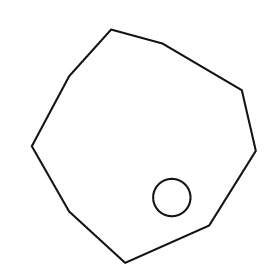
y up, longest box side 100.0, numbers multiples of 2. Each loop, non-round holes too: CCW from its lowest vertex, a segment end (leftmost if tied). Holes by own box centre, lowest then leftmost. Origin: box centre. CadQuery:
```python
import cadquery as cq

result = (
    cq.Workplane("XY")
    .moveTo(-8.0, -50.0)
    .lineTo(28.0, -34.0)
    .lineTo(48.0, -2.0)
    .lineTo(42.0, 24.0)
    .lineTo(8.0, 44.0)
    .lineTo(-14.0, 50.0)
    .lineTo(-32.0, 30.0)
    .lineTo(-48.0, 0.0)
    .lineTo(-32.0, -28.0)
    .close()
    .moveTo(12.0, -22.0)
    .circle(8.0)
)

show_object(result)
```